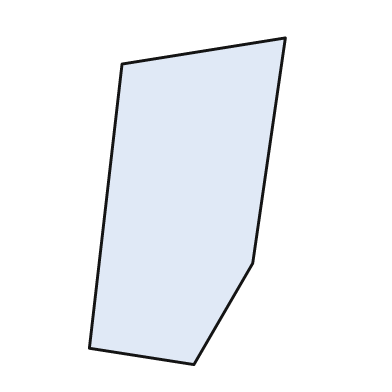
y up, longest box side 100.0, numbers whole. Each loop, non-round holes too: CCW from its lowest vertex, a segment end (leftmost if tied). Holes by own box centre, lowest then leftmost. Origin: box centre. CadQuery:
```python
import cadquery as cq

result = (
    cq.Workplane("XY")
    .moveTo(2.0, -50.0)
    .lineTo(20.0, -19.0)
    .lineTo(30.0, 50.0)
    .lineTo(-20.0, 42.0)
    .lineTo(-30.0, -45.0)
    .close()
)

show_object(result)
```